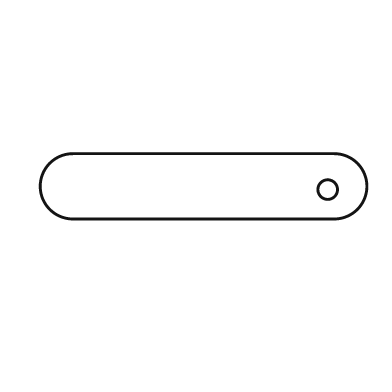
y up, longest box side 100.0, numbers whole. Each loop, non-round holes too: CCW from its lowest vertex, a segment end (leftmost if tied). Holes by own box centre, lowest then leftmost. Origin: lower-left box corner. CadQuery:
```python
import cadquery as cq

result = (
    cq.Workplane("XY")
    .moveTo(10.0, 0.0)
    .lineTo(90.0, 0.0)
    .threePointArc((100.0, 10.0), (90.0, 20.0))
    .lineTo(10.0, 20.0)
    .threePointArc((0.0, 10.0), (10.0, 0.0))
    .close()
    .moveTo(88.0, 9.0)
    .circle(3.0)
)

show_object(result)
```